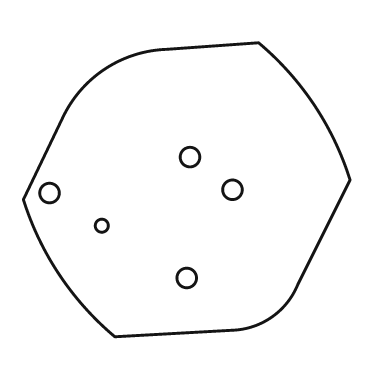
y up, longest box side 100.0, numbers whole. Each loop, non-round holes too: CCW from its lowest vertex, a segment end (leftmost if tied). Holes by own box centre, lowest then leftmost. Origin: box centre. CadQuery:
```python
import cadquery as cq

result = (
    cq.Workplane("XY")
    .moveTo(-22.0, -45.0)
    .lineTo(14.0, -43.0)
    .threePointArc((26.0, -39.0), (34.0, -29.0))
    .lineTo(50.0, 3.0)
    .threePointArc((39.0, 26.0), (22.0, 45.0))
    .lineTo(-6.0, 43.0)
    .threePointArc((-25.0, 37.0), (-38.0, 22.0))
    .lineTo(-50.0, -3.0)
    .threePointArc((-39.0, -26.0), (-22.0, -45.0))
    .close()
    .moveTo(0.0, -27.0)
    .circle(3.0)
    .moveTo(-26.0, -11.0)
    .circle(2.0)
    .moveTo(-42.0, -1.0)
    .circle(3.0)
    .moveTo(14.0, 0.0)
    .circle(3.0)
    .moveTo(1.0, 10.0)
    .circle(3.0)
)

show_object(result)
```